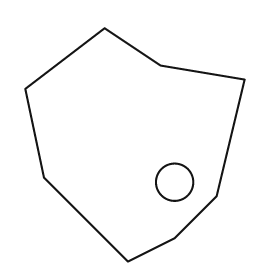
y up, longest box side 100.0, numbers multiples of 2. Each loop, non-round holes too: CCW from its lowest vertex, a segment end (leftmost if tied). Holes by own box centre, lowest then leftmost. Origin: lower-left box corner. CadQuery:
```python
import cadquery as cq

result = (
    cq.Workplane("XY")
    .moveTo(44.0, 0.0)
    .lineTo(64.0, 10.0)
    .lineTo(82.0, 28.0)
    .lineTo(94.0, 78.0)
    .lineTo(58.0, 84.0)
    .lineTo(34.0, 100.0)
    .lineTo(0.0, 74.0)
    .lineTo(8.0, 36.0)
    .close()
    .moveTo(64.0, 34.0)
    .circle(8.0)
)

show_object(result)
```